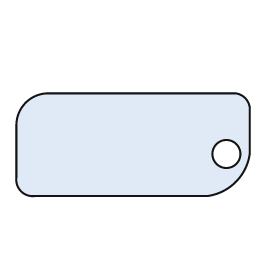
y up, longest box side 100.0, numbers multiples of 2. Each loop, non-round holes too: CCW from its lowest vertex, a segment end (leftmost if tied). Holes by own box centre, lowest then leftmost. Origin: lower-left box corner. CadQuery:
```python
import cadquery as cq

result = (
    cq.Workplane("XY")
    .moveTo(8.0, 0.0)
    .lineTo(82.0, 0.0)
    .threePointArc((94.0, 6.0), (100.0, 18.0))
    .lineTo(100.0, 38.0)
    .threePointArc((98.0, 42.0), (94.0, 44.0))
    .lineTo(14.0, 44.0)
    .threePointArc((4.0, 40.0), (0.0, 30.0))
    .lineTo(0.0, 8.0)
    .threePointArc((2.0, 2.0), (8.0, 0.0))
    .close()
    .moveTo(90.0, 18.0)
    .circle(6.0)
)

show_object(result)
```